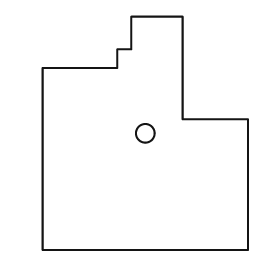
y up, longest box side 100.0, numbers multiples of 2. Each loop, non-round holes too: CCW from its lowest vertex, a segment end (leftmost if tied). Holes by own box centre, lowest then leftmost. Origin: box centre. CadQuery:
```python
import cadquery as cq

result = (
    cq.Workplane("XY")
    .moveTo(-44.0, -50.0)
    .lineTo(44.0, -50.0)
    .lineTo(44.0, 6.0)
    .lineTo(16.0, 6.0)
    .lineTo(16.0, 50.0)
    .lineTo(-6.0, 50.0)
    .lineTo(-6.0, 36.0)
    .lineTo(-12.0, 36.0)
    .lineTo(-12.0, 28.0)
    .lineTo(-44.0, 28.0)
    .close()
    .moveTo(0.0, 0.0)
    .circle(4.0)
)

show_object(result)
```